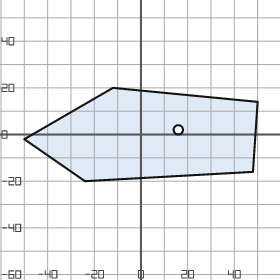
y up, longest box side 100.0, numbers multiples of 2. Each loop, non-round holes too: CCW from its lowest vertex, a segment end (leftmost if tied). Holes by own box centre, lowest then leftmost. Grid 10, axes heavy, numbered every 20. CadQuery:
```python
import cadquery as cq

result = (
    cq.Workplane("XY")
    .moveTo(-24.0, -20.0)
    .lineTo(48.0, -16.0)
    .lineTo(50.0, 14.0)
    .lineTo(-12.0, 20.0)
    .lineTo(-50.0, -2.0)
    .close()
    .moveTo(16.0, 2.0)
    .circle(2.0)
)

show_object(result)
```